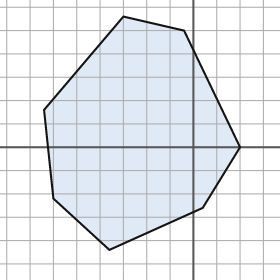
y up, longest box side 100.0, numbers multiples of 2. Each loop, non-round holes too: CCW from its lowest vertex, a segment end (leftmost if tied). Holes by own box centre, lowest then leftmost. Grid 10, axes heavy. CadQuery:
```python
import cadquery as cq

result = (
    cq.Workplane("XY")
    .moveTo(-36.0, -44.0)
    .lineTo(4.0, -26.0)
    .lineTo(20.0, 0.0)
    .lineTo(-4.0, 50.0)
    .lineTo(-30.0, 56.0)
    .lineTo(-64.0, 16.0)
    .lineTo(-60.0, -22.0)
    .close()
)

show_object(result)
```